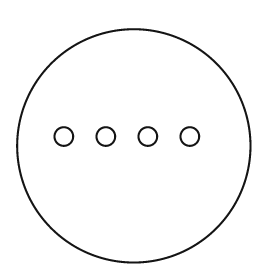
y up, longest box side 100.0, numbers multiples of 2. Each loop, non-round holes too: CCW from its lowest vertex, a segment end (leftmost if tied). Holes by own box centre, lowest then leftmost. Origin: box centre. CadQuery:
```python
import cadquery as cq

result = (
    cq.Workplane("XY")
    .moveTo(0.0, 0.0)
    .circle(50.0)
    .moveTo(-30.0, 4.0)
    .circle(4.0)
    .moveTo(-12.0, 4.0)
    .circle(4.0)
    .moveTo(6.0, 4.0)
    .circle(4.0)
    .moveTo(24.0, 4.0)
    .circle(4.0)
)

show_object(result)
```